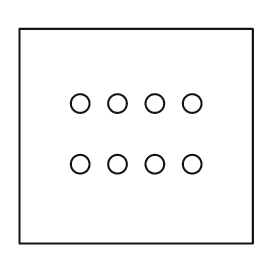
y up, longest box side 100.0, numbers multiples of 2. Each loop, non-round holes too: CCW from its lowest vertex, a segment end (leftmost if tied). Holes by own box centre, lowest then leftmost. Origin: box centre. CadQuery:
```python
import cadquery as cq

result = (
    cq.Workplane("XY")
    .moveTo(-50.0, -46.0)
    .lineTo(50.0, -46.0)
    .lineTo(50.0, 46.0)
    .lineTo(-50.0, 46.0)
    .close()
    .moveTo(-24.0, -12.0)
    .circle(4.0)
    .moveTo(-8.0, -12.0)
    .circle(4.0)
    .moveTo(8.0, -12.0)
    .circle(4.0)
    .moveTo(24.0, -12.0)
    .circle(4.0)
    .moveTo(-24.0, 14.0)
    .circle(4.0)
    .moveTo(-8.0, 14.0)
    .circle(4.0)
    .moveTo(8.0, 14.0)
    .circle(4.0)
    .moveTo(24.0, 14.0)
    .circle(4.0)
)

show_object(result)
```